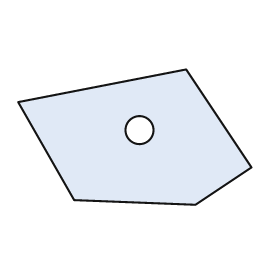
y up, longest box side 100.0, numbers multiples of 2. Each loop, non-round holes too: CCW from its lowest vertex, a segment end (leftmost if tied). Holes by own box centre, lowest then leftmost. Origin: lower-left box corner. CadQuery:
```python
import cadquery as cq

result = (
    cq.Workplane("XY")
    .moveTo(76.0, 0.0)
    .lineTo(100.0, 16.0)
    .lineTo(72.0, 58.0)
    .lineTo(0.0, 44.0)
    .lineTo(24.0, 2.0)
    .close()
    .moveTo(52.0, 32.0)
    .circle(6.0)
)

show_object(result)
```